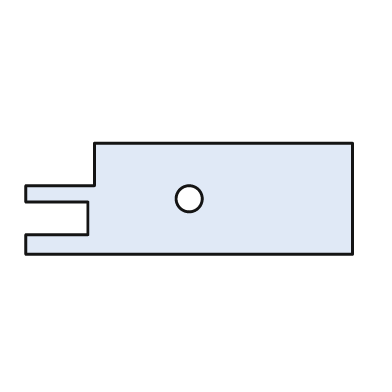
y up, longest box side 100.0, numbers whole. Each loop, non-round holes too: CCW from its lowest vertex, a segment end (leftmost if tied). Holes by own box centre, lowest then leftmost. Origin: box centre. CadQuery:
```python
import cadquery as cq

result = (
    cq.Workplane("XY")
    .moveTo(-50.0, -17.0)
    .lineTo(50.0, -17.0)
    .lineTo(50.0, 17.0)
    .lineTo(-29.0, 17.0)
    .lineTo(-29.0, 4.0)
    .lineTo(-50.0, 4.0)
    .lineTo(-50.0, -1.0)
    .lineTo(-31.0, -1.0)
    .lineTo(-31.0, -11.0)
    .lineTo(-50.0, -11.0)
    .close()
    .moveTo(0.0, 0.0)
    .circle(4.0)
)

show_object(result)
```